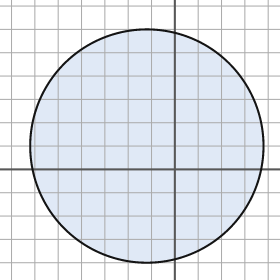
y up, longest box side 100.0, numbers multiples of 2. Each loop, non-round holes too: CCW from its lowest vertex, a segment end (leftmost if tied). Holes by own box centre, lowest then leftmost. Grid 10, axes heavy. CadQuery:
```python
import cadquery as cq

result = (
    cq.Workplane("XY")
    .moveTo(-12.0, 10.0)
    .circle(50.0)
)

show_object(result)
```